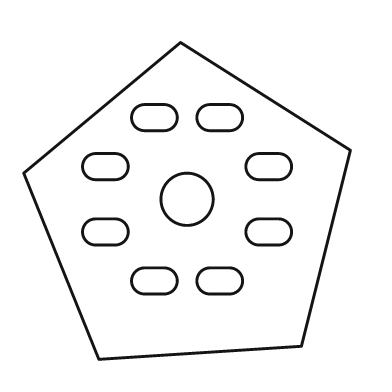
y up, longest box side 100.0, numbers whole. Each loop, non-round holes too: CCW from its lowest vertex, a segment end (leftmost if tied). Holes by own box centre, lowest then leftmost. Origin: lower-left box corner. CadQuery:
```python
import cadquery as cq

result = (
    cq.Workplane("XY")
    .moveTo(23.0, 0.0)
    .lineTo(85.0, 4.0)
    .lineTo(100.0, 64.0)
    .lineTo(48.0, 97.0)
    .lineTo(0.0, 57.0)
    .close()
    .moveTo(37.0, 20.0)
    .lineTo(43.0, 20.0)
    .threePointArc((47.0, 24.0), (43.0, 28.0))
    .lineTo(37.0, 28.0)
    .threePointArc((33.0, 24.0), (37.0, 20.0))
    .close()
    .moveTo(57.0, 20.0)
    .lineTo(63.0, 20.0)
    .threePointArc((67.0, 24.0), (63.0, 28.0))
    .lineTo(57.0, 28.0)
    .threePointArc((53.0, 24.0), (57.0, 20.0))
    .close()
    .moveTo(22.0, 35.0)
    .lineTo(28.0, 35.0)
    .threePointArc((32.0, 39.0), (28.0, 43.0))
    .lineTo(22.0, 43.0)
    .threePointArc((18.0, 39.0), (22.0, 35.0))
    .close()
    .moveTo(72.0, 35.0)
    .lineTo(78.0, 35.0)
    .threePointArc((82.0, 39.0), (78.0, 43.0))
    .lineTo(72.0, 43.0)
    .threePointArc((68.0, 39.0), (72.0, 35.0))
    .close()
    .moveTo(50.0, 49.0)
    .circle(8.0)
    .moveTo(22.0, 55.0)
    .lineTo(28.0, 55.0)
    .threePointArc((32.0, 59.0), (28.0, 63.0))
    .lineTo(22.0, 63.0)
    .threePointArc((18.0, 59.0), (22.0, 55.0))
    .close()
    .moveTo(72.0, 55.0)
    .lineTo(78.0, 55.0)
    .threePointArc((82.0, 59.0), (78.0, 63.0))
    .lineTo(72.0, 63.0)
    .threePointArc((68.0, 59.0), (72.0, 55.0))
    .close()
    .moveTo(37.0, 70.0)
    .lineTo(43.0, 70.0)
    .threePointArc((47.0, 74.0), (43.0, 78.0))
    .lineTo(37.0, 78.0)
    .threePointArc((33.0, 74.0), (37.0, 70.0))
    .close()
    .moveTo(57.0, 70.0)
    .lineTo(63.0, 70.0)
    .threePointArc((67.0, 74.0), (63.0, 78.0))
    .lineTo(57.0, 78.0)
    .threePointArc((53.0, 74.0), (57.0, 70.0))
    .close()
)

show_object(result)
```